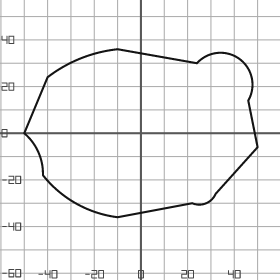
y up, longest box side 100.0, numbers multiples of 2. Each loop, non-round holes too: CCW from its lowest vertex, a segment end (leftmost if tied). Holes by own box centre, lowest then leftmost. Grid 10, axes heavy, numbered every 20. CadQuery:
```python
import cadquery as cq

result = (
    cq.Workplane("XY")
    .moveTo(-10.0, -36.0)
    .lineTo(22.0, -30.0)
    .threePointArc((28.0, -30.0), (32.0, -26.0))
    .lineTo(50.0, -6.0)
    .lineTo(46.0, 14.0)
    .threePointArc((42.0, 32.0), (24.0, 30.0))
    .lineTo(-10.0, 36.0)
    .threePointArc((-26.0, 32.0), (-40.0, 24.0))
    .lineTo(-50.0, 0.0)
    .threePointArc((-44.0, -8.0), (-42.0, -18.0))
    .threePointArc((-28.0, -30.0), (-10.0, -36.0))
    .close()
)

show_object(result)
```